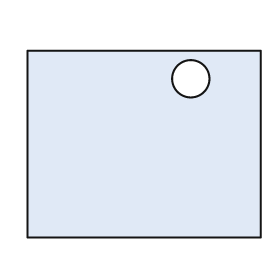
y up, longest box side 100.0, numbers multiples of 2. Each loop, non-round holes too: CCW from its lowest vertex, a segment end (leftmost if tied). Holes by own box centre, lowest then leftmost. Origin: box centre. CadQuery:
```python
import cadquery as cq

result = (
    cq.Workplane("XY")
    .moveTo(-50.0, -40.0)
    .lineTo(50.0, -40.0)
    .lineTo(50.0, 40.0)
    .lineTo(-50.0, 40.0)
    .close()
    .moveTo(20.0, 28.0)
    .circle(8.0)
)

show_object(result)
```